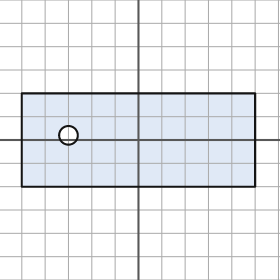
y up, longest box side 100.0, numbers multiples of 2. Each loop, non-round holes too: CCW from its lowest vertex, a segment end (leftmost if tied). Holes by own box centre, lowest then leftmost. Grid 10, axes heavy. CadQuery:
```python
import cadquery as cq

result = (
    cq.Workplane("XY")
    .moveTo(-50.0, -20.0)
    .lineTo(50.0, -20.0)
    .lineTo(50.0, 20.0)
    .lineTo(-50.0, 20.0)
    .close()
    .moveTo(-30.0, 2.0)
    .circle(4.0)
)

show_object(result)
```